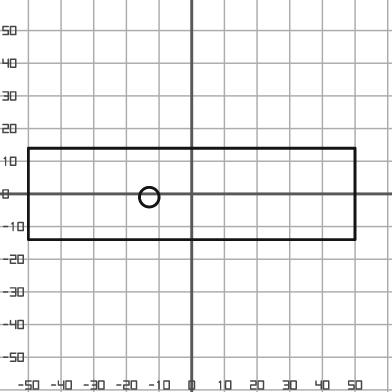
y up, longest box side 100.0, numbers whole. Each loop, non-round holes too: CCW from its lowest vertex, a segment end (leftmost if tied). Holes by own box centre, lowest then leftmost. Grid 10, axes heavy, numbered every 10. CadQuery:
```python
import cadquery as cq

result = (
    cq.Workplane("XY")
    .moveTo(-50.0, -14.0)
    .lineTo(50.0, -14.0)
    .lineTo(50.0, 14.0)
    .lineTo(-50.0, 14.0)
    .close()
    .moveTo(-13.0, -1.0)
    .circle(3.0)
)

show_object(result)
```